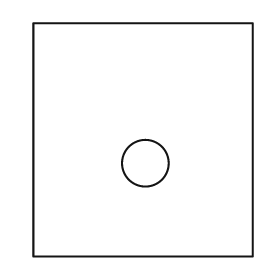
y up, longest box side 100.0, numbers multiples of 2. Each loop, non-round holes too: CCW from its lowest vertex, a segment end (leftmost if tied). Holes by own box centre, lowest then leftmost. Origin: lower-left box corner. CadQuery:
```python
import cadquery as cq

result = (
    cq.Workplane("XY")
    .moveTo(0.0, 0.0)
    .lineTo(94.0, 0.0)
    .lineTo(94.0, 100.0)
    .lineTo(0.0, 100.0)
    .close()
    .moveTo(48.0, 40.0)
    .circle(10.0)
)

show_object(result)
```